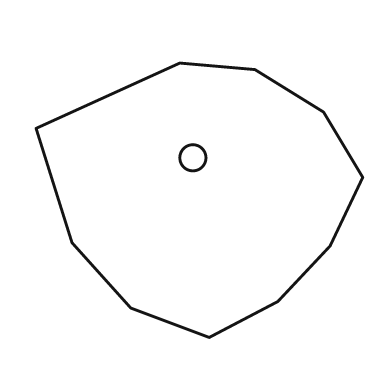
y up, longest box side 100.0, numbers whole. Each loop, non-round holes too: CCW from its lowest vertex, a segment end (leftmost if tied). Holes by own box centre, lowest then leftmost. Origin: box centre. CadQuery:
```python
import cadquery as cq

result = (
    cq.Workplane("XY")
    .moveTo(3.0, -42.0)
    .lineTo(24.0, -31.0)
    .lineTo(40.0, -14.0)
    .lineTo(50.0, 7.0)
    .lineTo(38.0, 27.0)
    .lineTo(17.0, 40.0)
    .lineTo(-6.0, 42.0)
    .lineTo(-50.0, 22.0)
    .lineTo(-39.0, -13.0)
    .lineTo(-21.0, -33.0)
    .close()
    .moveTo(-2.0, 13.0)
    .circle(4.0)
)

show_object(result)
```